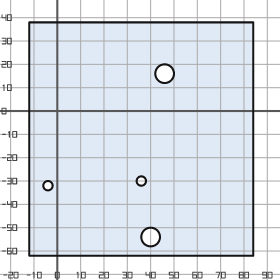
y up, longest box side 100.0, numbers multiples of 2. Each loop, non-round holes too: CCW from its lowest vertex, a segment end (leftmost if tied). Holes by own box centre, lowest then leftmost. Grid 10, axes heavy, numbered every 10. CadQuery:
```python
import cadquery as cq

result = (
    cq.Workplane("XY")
    .moveTo(-12.0, -62.0)
    .lineTo(84.0, -62.0)
    .lineTo(84.0, 38.0)
    .lineTo(-12.0, 38.0)
    .close()
    .moveTo(40.0, -54.0)
    .circle(4.0)
    .moveTo(-4.0, -32.0)
    .circle(2.0)
    .moveTo(36.0, -30.0)
    .circle(2.0)
    .moveTo(46.0, 16.0)
    .circle(4.0)
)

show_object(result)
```